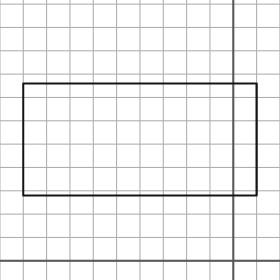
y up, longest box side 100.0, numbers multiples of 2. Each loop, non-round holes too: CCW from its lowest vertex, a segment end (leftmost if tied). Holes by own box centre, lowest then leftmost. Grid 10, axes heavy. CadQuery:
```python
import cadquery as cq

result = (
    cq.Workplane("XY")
    .moveTo(-90.0, 28.0)
    .lineTo(10.0, 28.0)
    .lineTo(10.0, 76.0)
    .lineTo(-90.0, 76.0)
    .close()
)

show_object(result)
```